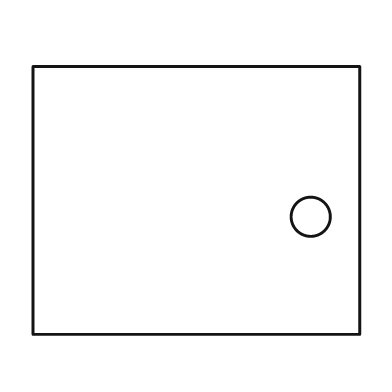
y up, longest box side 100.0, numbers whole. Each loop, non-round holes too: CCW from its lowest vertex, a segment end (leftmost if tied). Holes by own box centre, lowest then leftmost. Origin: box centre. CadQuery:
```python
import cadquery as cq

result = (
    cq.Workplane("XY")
    .moveTo(-50.0, -41.0)
    .lineTo(50.0, -41.0)
    .lineTo(50.0, 41.0)
    .lineTo(-50.0, 41.0)
    .close()
    .moveTo(35.0, -5.0)
    .circle(6.0)
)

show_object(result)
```